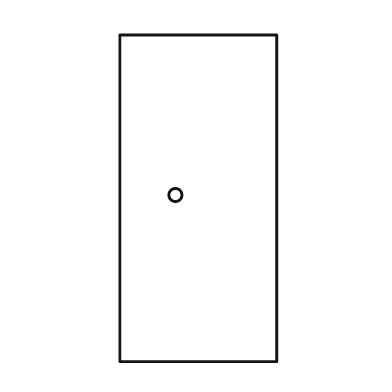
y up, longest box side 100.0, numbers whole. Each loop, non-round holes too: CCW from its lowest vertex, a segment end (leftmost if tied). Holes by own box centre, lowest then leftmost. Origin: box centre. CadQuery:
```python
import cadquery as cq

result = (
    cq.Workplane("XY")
    .moveTo(-24.0, -50.0)
    .lineTo(24.0, -50.0)
    .lineTo(24.0, 50.0)
    .lineTo(-24.0, 50.0)
    .close()
    .moveTo(-7.0, 1.0)
    .circle(2.0)
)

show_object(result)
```